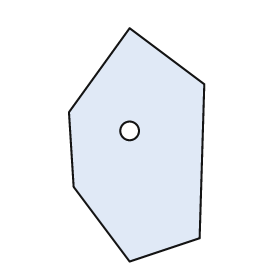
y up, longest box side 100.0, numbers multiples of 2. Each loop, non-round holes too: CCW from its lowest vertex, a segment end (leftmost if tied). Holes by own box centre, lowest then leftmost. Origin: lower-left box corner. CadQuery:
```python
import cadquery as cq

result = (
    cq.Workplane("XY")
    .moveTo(26.0, 0.0)
    .lineTo(56.0, 10.0)
    .lineTo(58.0, 76.0)
    .lineTo(26.0, 100.0)
    .lineTo(0.0, 64.0)
    .lineTo(2.0, 32.0)
    .close()
    .moveTo(26.0, 56.0)
    .circle(4.0)
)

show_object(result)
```